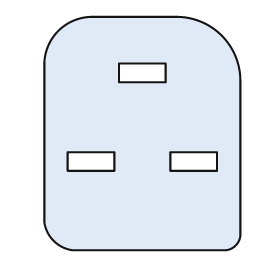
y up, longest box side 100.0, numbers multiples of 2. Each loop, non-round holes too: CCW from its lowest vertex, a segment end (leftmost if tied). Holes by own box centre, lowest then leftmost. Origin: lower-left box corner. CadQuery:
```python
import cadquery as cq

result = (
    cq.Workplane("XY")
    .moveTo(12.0, 0.0)
    .lineTo(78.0, 0.0)
    .threePointArc((82.0, 2.0), (84.0, 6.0))
    .lineTo(84.0, 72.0)
    .threePointArc((76.0, 92.0), (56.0, 100.0))
    .lineTo(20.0, 100.0)
    .threePointArc((6.0, 94.0), (0.0, 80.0))
    .lineTo(0.0, 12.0)
    .threePointArc((4.0, 4.0), (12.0, 0.0))
    .close()
    .moveTo(10.0, 34.0)
    .lineTo(30.0, 34.0)
    .lineTo(30.0, 42.0)
    .lineTo(10.0, 42.0)
    .close()
    .moveTo(54.0, 34.0)
    .lineTo(74.0, 34.0)
    .lineTo(74.0, 42.0)
    .lineTo(54.0, 42.0)
    .close()
    .moveTo(32.0, 72.0)
    .lineTo(52.0, 72.0)
    .lineTo(52.0, 80.0)
    .lineTo(32.0, 80.0)
    .close()
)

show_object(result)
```